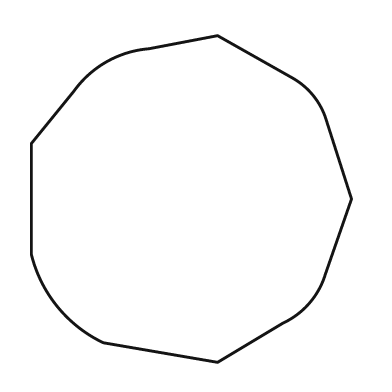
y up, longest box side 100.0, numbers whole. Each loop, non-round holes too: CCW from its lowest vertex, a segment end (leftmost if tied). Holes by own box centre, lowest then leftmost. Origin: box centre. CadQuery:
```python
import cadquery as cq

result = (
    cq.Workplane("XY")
    .moveTo(8.0, -50.0)
    .lineTo(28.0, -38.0)
    .threePointArc((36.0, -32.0), (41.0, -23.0))
    .lineTo(49.0, 0.0)
    .lineTo(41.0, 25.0)
    .threePointArc((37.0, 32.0), (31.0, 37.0))
    .lineTo(8.0, 50.0)
    .lineTo(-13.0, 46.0)
    .threePointArc((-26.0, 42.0), (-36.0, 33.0))
    .lineTo(-49.0, 17.0)
    .lineTo(-49.0, -17.0)
    .threePointArc((-41.0, -33.0), (-27.0, -44.0))
    .close()
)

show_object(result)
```